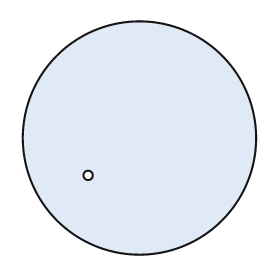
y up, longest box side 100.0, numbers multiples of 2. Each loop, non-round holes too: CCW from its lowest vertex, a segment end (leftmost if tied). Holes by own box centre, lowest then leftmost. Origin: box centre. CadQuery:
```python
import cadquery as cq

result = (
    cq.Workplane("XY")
    .moveTo(0.0, 0.0)
    .circle(50.0)
    .moveTo(-22.0, -16.0)
    .circle(2.0)
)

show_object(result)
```